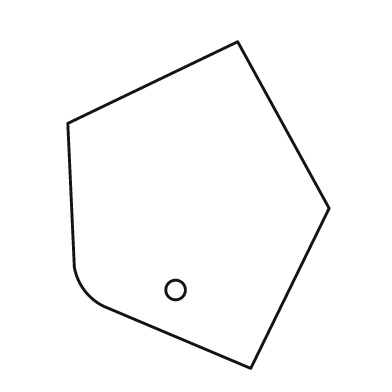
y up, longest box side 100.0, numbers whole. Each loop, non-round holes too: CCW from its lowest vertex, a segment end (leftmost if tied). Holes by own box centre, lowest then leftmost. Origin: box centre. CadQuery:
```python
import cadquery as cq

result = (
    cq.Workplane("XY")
    .moveTo(16.0, -50.0)
    .lineTo(40.0, -1.0)
    .lineTo(12.0, 50.0)
    .lineTo(-40.0, 25.0)
    .lineTo(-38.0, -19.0)
    .threePointArc((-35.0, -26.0), (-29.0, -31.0))
    .close()
    .moveTo(-7.0, -26.0)
    .circle(3.0)
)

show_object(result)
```